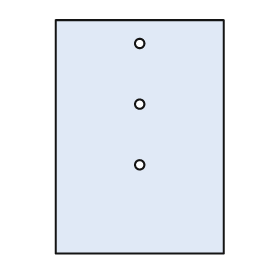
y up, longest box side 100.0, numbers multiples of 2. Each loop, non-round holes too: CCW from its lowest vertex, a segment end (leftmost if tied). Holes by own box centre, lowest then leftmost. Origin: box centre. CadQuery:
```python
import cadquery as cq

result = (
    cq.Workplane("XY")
    .moveTo(-36.0, -50.0)
    .lineTo(36.0, -50.0)
    .lineTo(36.0, 50.0)
    .lineTo(-36.0, 50.0)
    .close()
    .moveTo(0.0, -12.0)
    .circle(2.0)
    .moveTo(0.0, 14.0)
    .circle(2.0)
    .moveTo(0.0, 40.0)
    .circle(2.0)
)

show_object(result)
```